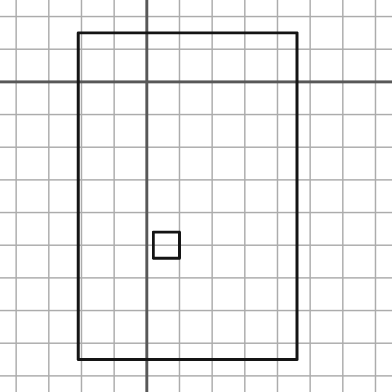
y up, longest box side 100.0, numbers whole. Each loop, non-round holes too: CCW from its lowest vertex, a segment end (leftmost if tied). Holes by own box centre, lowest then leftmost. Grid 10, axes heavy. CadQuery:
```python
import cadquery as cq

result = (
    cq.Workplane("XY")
    .moveTo(-21.0, -85.0)
    .lineTo(46.0, -85.0)
    .lineTo(46.0, 15.0)
    .lineTo(-21.0, 15.0)
    .close()
    .moveTo(2.0, -54.0)
    .lineTo(10.0, -54.0)
    .lineTo(10.0, -46.0)
    .lineTo(2.0, -46.0)
    .close()
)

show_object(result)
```